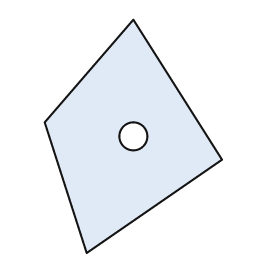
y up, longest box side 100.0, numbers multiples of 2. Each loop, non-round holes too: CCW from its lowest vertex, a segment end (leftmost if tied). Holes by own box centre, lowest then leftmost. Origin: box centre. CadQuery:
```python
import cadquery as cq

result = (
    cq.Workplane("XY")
    .moveTo(-20.0, -50.0)
    .lineTo(38.0, -10.0)
    .lineTo(0.0, 50.0)
    .lineTo(-38.0, 6.0)
    .close()
    .moveTo(0.0, 0.0)
    .circle(6.0)
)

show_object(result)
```